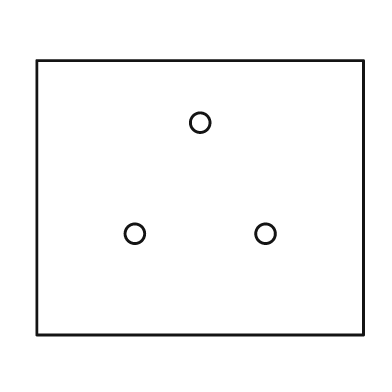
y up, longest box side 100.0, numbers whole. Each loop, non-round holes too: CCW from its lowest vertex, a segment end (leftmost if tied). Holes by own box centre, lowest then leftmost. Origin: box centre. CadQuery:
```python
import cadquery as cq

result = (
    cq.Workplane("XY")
    .moveTo(-50.0, -42.0)
    .lineTo(50.0, -42.0)
    .lineTo(50.0, 42.0)
    .lineTo(-50.0, 42.0)
    .close()
    .moveTo(-20.0, -11.0)
    .circle(3.0)
    .moveTo(20.0, -11.0)
    .circle(3.0)
    .moveTo(0.0, 23.0)
    .circle(3.0)
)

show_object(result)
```